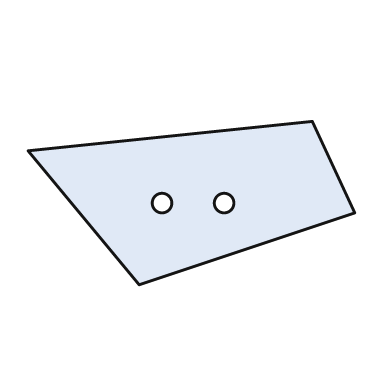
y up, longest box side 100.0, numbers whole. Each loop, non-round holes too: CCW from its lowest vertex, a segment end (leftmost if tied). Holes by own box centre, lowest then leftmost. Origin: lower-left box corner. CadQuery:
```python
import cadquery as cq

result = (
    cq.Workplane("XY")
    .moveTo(34.0, 0.0)
    .lineTo(100.0, 22.0)
    .lineTo(87.0, 50.0)
    .lineTo(0.0, 41.0)
    .close()
    .moveTo(41.0, 25.0)
    .circle(3.0)
    .moveTo(60.0, 25.0)
    .circle(3.0)
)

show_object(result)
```